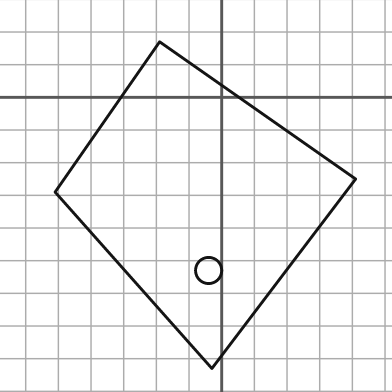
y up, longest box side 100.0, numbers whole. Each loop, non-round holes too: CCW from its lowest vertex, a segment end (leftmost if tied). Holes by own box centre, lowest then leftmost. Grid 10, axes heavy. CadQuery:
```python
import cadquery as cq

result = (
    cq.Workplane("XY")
    .moveTo(-3.0, -83.0)
    .lineTo(41.0, -25.0)
    .lineTo(-19.0, 17.0)
    .lineTo(-51.0, -29.0)
    .close()
    .moveTo(-4.0, -53.0)
    .circle(4.0)
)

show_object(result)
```